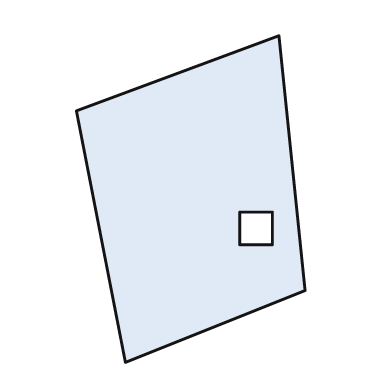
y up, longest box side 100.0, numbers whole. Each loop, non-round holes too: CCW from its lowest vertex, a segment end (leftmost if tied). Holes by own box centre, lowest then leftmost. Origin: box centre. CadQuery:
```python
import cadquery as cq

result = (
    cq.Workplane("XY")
    .moveTo(-20.0, -50.0)
    .lineTo(35.0, -28.0)
    .lineTo(27.0, 50.0)
    .lineTo(-35.0, 27.0)
    .close()
    .moveTo(15.0, -14.0)
    .lineTo(25.0, -14.0)
    .lineTo(25.0, -4.0)
    .lineTo(15.0, -4.0)
    .close()
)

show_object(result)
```